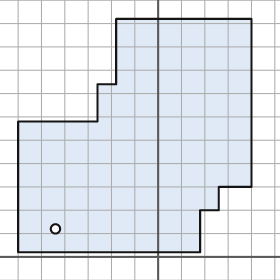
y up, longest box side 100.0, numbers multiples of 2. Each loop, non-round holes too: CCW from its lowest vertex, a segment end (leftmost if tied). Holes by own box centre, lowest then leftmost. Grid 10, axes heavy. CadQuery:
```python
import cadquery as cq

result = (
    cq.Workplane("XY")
    .moveTo(-60.0, 2.0)
    .lineTo(18.0, 2.0)
    .lineTo(18.0, 20.0)
    .lineTo(26.0, 20.0)
    .lineTo(26.0, 30.0)
    .lineTo(40.0, 30.0)
    .lineTo(40.0, 102.0)
    .lineTo(-18.0, 102.0)
    .lineTo(-18.0, 74.0)
    .lineTo(-26.0, 74.0)
    .lineTo(-26.0, 58.0)
    .lineTo(-60.0, 58.0)
    .close()
    .moveTo(-44.0, 12.0)
    .circle(2.0)
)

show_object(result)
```